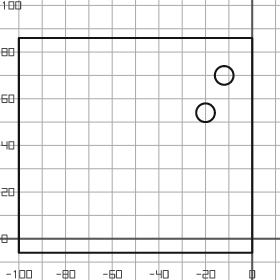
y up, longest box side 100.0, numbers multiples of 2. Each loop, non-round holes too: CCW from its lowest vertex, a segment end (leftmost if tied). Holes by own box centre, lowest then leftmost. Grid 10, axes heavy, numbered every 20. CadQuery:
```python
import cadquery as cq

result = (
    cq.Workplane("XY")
    .moveTo(-100.0, -6.0)
    .lineTo(0.0, -6.0)
    .lineTo(0.0, 86.0)
    .lineTo(-100.0, 86.0)
    .close()
    .moveTo(-20.0, 54.0)
    .circle(4.0)
    .moveTo(-12.0, 70.0)
    .circle(4.0)
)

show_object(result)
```